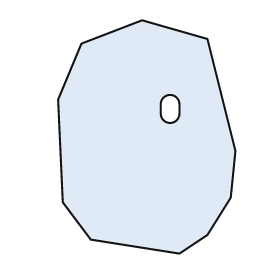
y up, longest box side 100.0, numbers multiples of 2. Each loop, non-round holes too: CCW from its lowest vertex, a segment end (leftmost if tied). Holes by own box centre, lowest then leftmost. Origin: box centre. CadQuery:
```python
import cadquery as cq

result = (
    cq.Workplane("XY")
    .moveTo(14.0, -50.0)
    .lineTo(26.0, -42.0)
    .lineTo(36.0, -26.0)
    .lineTo(38.0, -6.0)
    .lineTo(26.0, 42.0)
    .lineTo(-2.0, 50.0)
    .lineTo(-28.0, 40.0)
    .lineTo(-38.0, 16.0)
    .lineTo(-36.0, -28.0)
    .lineTo(-24.0, -44.0)
    .close()
    .moveTo(6.0, 10.0)
    .threePointArc((10.0, 6.0), (14.0, 10.0))
    .lineTo(14.0, 14.0)
    .threePointArc((10.0, 18.0), (6.0, 14.0))
    .close()
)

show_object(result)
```